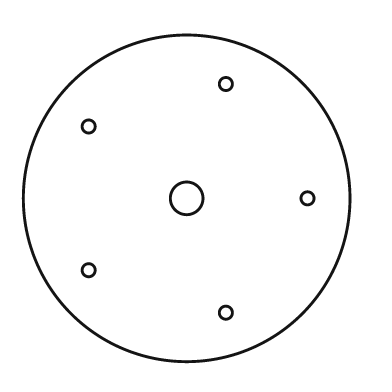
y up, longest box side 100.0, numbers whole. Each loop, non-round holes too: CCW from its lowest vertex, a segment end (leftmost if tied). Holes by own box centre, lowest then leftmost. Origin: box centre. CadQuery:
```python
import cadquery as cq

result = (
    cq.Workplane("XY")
    .moveTo(0.0, 0.0)
    .circle(50.0)
    .moveTo(12.0, -35.0)
    .circle(2.0)
    .moveTo(-30.0, -22.0)
    .circle(2.0)
    .moveTo(0.0, 0.0)
    .circle(5.0)
    .moveTo(37.0, 0.0)
    .circle(2.0)
    .moveTo(-30.0, 22.0)
    .circle(2.0)
    .moveTo(12.0, 35.0)
    .circle(2.0)
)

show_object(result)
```